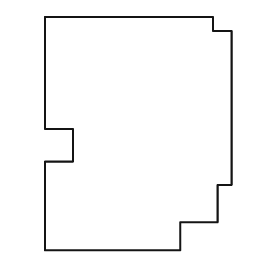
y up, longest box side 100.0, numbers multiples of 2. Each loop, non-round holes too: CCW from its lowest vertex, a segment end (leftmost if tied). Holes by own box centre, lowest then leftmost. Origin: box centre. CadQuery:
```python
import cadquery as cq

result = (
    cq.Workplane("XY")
    .moveTo(-40.0, -50.0)
    .lineTo(18.0, -50.0)
    .lineTo(18.0, -38.0)
    .lineTo(34.0, -38.0)
    .lineTo(34.0, -22.0)
    .lineTo(40.0, -22.0)
    .lineTo(40.0, 44.0)
    .lineTo(32.0, 44.0)
    .lineTo(32.0, 50.0)
    .lineTo(-40.0, 50.0)
    .lineTo(-40.0, 2.0)
    .lineTo(-28.0, 2.0)
    .lineTo(-28.0, -12.0)
    .lineTo(-40.0, -12.0)
    .close()
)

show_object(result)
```